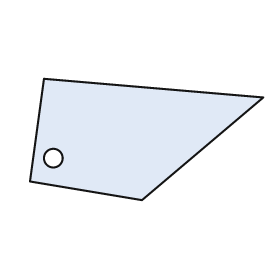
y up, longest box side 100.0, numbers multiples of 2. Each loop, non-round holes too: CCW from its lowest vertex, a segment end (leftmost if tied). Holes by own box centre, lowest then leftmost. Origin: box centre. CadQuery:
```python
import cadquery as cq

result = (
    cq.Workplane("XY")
    .moveTo(-2.0, -26.0)
    .lineTo(50.0, 18.0)
    .lineTo(-44.0, 26.0)
    .lineTo(-50.0, -18.0)
    .close()
    .moveTo(-40.0, -8.0)
    .circle(4.0)
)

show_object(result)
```